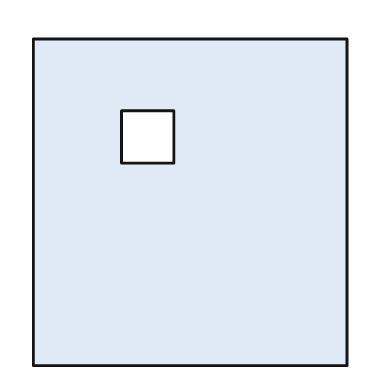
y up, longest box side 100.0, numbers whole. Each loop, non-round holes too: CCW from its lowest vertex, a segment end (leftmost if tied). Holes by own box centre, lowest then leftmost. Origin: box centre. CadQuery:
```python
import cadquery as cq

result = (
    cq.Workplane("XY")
    .moveTo(-48.0, -50.0)
    .lineTo(48.0, -50.0)
    .lineTo(48.0, 50.0)
    .lineTo(-48.0, 50.0)
    .close()
    .moveTo(-21.0, 12.0)
    .lineTo(-5.0, 12.0)
    .lineTo(-5.0, 28.0)
    .lineTo(-21.0, 28.0)
    .close()
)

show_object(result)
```